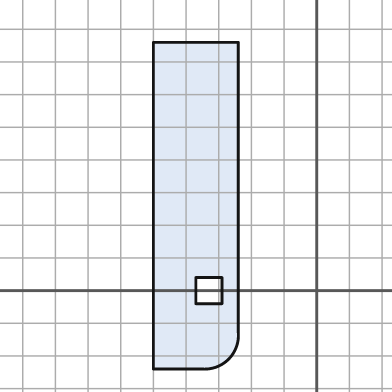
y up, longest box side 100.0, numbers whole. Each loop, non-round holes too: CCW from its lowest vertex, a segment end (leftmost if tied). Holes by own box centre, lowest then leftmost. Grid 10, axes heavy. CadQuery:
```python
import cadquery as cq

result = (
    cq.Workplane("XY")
    .moveTo(-50.0, -24.0)
    .lineTo(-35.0, -24.0)
    .threePointArc((-27.0, -21.0), (-24.0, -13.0))
    .lineTo(-24.0, 76.0)
    .lineTo(-50.0, 76.0)
    .close()
    .moveTo(-37.0, -4.0)
    .lineTo(-29.0, -4.0)
    .lineTo(-29.0, 4.0)
    .lineTo(-37.0, 4.0)
    .close()
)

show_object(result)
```